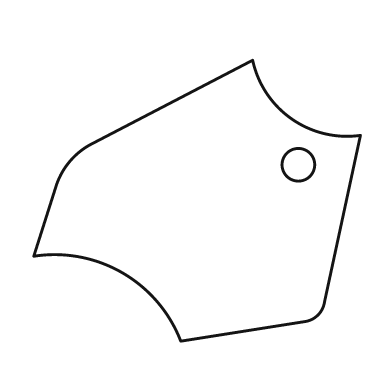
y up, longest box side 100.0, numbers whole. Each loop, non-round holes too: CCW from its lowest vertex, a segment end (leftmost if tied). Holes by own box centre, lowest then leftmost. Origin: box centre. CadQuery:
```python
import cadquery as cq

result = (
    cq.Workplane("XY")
    .moveTo(-5.0, -43.0)
    .lineTo(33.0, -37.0)
    .threePointArc((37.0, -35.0), (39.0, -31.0))
    .lineTo(50.0, 20.0)
    .threePointArc((29.0, 25.0), (17.0, 43.0))
    .lineTo(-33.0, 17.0)
    .threePointArc((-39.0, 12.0), (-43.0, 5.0))
    .lineTo(-50.0, -17.0)
    .threePointArc((-23.0, -22.0), (-5.0, -43.0))
    .close()
    .moveTo(31.0, 11.0)
    .circle(5.0)
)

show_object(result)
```